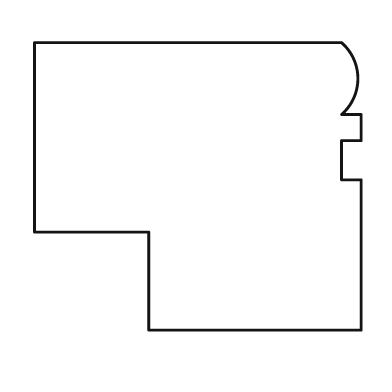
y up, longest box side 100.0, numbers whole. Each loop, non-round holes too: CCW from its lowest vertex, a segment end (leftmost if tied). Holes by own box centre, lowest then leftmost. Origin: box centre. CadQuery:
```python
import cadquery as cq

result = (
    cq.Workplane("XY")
    .moveTo(-15.0, -44.0)
    .lineTo(50.0, -44.0)
    .lineTo(50.0, 2.0)
    .lineTo(44.0, 2.0)
    .lineTo(44.0, 14.0)
    .lineTo(50.0, 14.0)
    .lineTo(50.0, 22.0)
    .lineTo(44.0, 22.0)
    .threePointArc((49.0, 33.0), (44.0, 44.0))
    .lineTo(-50.0, 44.0)
    .lineTo(-50.0, -14.0)
    .lineTo(-15.0, -14.0)
    .close()
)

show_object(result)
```